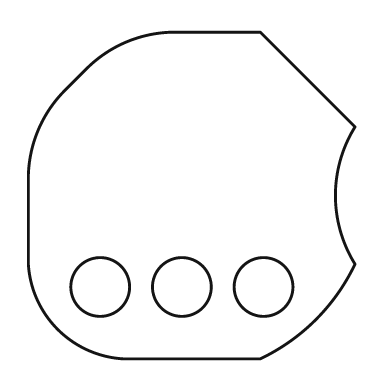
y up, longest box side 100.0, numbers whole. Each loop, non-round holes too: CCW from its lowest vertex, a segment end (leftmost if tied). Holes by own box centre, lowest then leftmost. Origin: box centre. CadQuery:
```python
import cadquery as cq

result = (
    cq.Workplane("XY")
    .moveTo(-21.0, -50.0)
    .lineTo(21.0, -50.0)
    .threePointArc((38.0, -38.0), (50.0, -21.0))
    .threePointArc((44.0, 0.0), (50.0, 21.0))
    .lineTo(21.0, 50.0)
    .lineTo(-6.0, 50.0)
    .threePointArc((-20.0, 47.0), (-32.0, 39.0))
    .lineTo(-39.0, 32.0)
    .threePointArc((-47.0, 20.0), (-50.0, 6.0))
    .lineTo(-50.0, -21.0)
    .threePointArc((-41.0, -41.0), (-21.0, -50.0))
    .close()
    .moveTo(-28.0, -28.0)
    .circle(9.0)
    .moveTo(-3.0, -28.0)
    .circle(9.0)
    .moveTo(22.0, -28.0)
    .circle(9.0)
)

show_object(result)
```